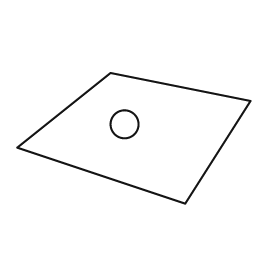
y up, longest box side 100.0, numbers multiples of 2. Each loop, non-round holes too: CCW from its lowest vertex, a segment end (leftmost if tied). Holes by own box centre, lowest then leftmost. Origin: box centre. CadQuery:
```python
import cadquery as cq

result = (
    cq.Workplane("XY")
    .moveTo(22.0, -28.0)
    .lineTo(50.0, 16.0)
    .lineTo(-10.0, 28.0)
    .lineTo(-50.0, -4.0)
    .close()
    .moveTo(-4.0, 6.0)
    .circle(6.0)
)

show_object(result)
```